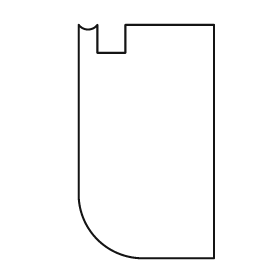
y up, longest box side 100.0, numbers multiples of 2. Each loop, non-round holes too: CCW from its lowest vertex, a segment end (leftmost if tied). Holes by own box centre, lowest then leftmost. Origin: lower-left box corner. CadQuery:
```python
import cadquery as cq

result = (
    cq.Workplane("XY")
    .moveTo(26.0, 0.0)
    .lineTo(58.0, 0.0)
    .lineTo(58.0, 100.0)
    .lineTo(20.0, 100.0)
    .lineTo(20.0, 88.0)
    .lineTo(8.0, 88.0)
    .lineTo(8.0, 100.0)
    .threePointArc((4.0, 98.0), (0.0, 100.0))
    .lineTo(0.0, 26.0)
    .threePointArc((8.0, 8.0), (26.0, 0.0))
    .close()
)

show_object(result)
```